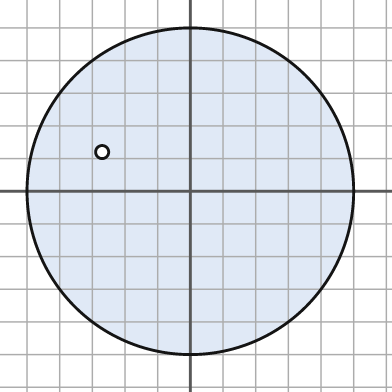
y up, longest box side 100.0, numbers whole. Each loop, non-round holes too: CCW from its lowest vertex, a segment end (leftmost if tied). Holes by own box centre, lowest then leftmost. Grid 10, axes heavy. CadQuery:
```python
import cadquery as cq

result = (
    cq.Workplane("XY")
    .moveTo(0.0, 0.0)
    .circle(50.0)
    .moveTo(-27.0, 12.0)
    .circle(2.0)
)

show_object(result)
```